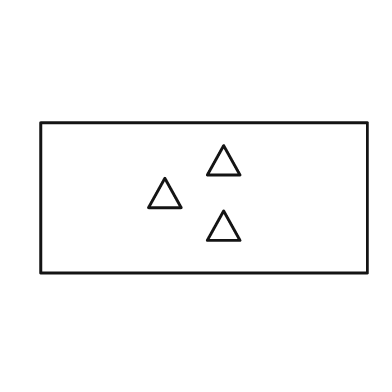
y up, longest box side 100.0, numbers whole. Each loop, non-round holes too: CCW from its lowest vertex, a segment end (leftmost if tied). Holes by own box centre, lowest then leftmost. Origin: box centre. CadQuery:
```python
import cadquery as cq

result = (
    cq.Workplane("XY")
    .moveTo(-50.0, -23.0)
    .lineTo(50.0, -23.0)
    .lineTo(50.0, 23.0)
    .lineTo(-50.0, 23.0)
    .close()
    .moveTo(1.0, -13.0)
    .lineTo(11.0, -13.0)
    .lineTo(6.0, -4.0)
    .close()
    .moveTo(-17.0, -3.0)
    .lineTo(-7.0, -3.0)
    .lineTo(-12.0, 6.0)
    .close()
    .moveTo(1.0, 7.0)
    .lineTo(11.0, 7.0)
    .lineTo(6.0, 16.0)
    .close()
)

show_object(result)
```